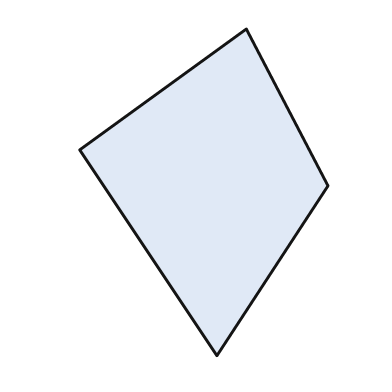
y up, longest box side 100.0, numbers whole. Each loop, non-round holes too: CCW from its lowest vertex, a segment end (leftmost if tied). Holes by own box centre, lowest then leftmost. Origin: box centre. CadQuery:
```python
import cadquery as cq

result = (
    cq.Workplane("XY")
    .moveTo(4.0, -50.0)
    .lineTo(38.0, 2.0)
    .lineTo(13.0, 50.0)
    .lineTo(-38.0, 13.0)
    .close()
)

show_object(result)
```